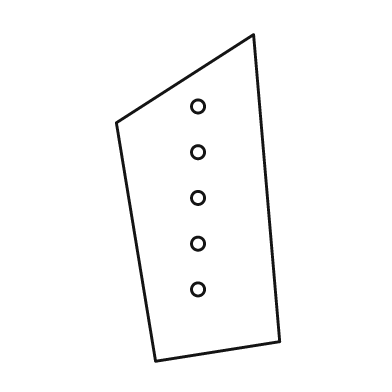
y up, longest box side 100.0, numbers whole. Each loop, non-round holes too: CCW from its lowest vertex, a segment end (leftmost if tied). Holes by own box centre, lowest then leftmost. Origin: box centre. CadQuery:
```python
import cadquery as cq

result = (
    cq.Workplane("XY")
    .moveTo(-13.0, -50.0)
    .lineTo(25.0, -44.0)
    .lineTo(17.0, 50.0)
    .lineTo(-25.0, 23.0)
    .close()
    .moveTo(0.0, -28.0)
    .circle(2.0)
    .moveTo(0.0, -14.0)
    .circle(2.0)
    .moveTo(0.0, 0.0)
    .circle(2.0)
    .moveTo(0.0, 14.0)
    .circle(2.0)
    .moveTo(0.0, 28.0)
    .circle(2.0)
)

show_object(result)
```